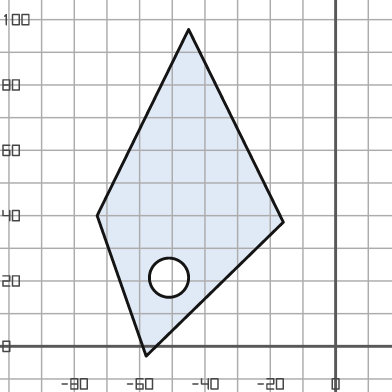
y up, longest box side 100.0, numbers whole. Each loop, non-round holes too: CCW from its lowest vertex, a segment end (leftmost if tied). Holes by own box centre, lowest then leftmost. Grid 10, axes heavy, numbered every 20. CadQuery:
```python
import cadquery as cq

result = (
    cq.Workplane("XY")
    .moveTo(-58.0, -3.0)
    .lineTo(-16.0, 38.0)
    .lineTo(-45.0, 97.0)
    .lineTo(-73.0, 40.0)
    .close()
    .moveTo(-51.0, 21.0)
    .circle(6.0)
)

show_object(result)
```